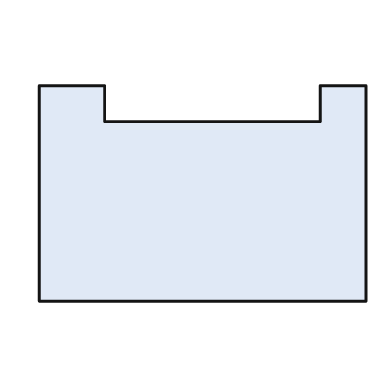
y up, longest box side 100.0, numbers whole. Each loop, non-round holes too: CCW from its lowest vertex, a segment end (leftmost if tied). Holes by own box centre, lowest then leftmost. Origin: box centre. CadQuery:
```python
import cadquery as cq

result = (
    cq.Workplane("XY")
    .moveTo(-50.0, -33.0)
    .lineTo(50.0, -33.0)
    .lineTo(50.0, 33.0)
    .lineTo(36.0, 33.0)
    .lineTo(36.0, 22.0)
    .lineTo(-30.0, 22.0)
    .lineTo(-30.0, 33.0)
    .lineTo(-50.0, 33.0)
    .close()
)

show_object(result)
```